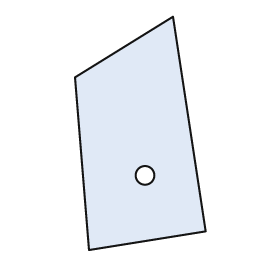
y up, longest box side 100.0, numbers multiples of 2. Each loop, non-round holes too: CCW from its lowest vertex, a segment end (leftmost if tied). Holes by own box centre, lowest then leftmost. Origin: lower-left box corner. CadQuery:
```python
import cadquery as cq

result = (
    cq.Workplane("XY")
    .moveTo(6.0, 0.0)
    .lineTo(56.0, 8.0)
    .lineTo(42.0, 100.0)
    .lineTo(0.0, 74.0)
    .close()
    .moveTo(30.0, 32.0)
    .circle(4.0)
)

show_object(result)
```